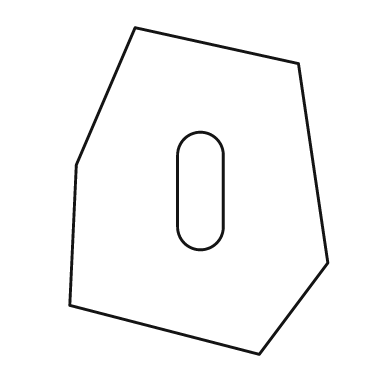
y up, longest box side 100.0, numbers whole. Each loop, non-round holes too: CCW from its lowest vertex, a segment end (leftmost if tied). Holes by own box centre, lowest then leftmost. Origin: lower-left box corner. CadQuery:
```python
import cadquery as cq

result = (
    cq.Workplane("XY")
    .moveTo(58.0, 0.0)
    .lineTo(79.0, 28.0)
    .lineTo(70.0, 89.0)
    .lineTo(20.0, 100.0)
    .lineTo(2.0, 58.0)
    .lineTo(0.0, 15.0)
    .close()
    .moveTo(33.0, 39.0)
    .threePointArc((40.0, 32.0), (47.0, 39.0))
    .lineTo(47.0, 61.0)
    .threePointArc((40.0, 68.0), (33.0, 61.0))
    .close()
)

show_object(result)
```